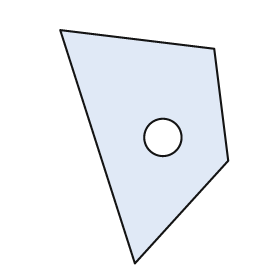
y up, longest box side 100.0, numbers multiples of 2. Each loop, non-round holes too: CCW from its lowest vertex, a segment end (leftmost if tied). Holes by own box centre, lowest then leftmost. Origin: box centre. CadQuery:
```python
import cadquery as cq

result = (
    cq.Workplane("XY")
    .moveTo(-4.0, -50.0)
    .lineTo(36.0, -6.0)
    .lineTo(30.0, 42.0)
    .lineTo(-36.0, 50.0)
    .close()
    .moveTo(8.0, 4.0)
    .circle(8.0)
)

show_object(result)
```